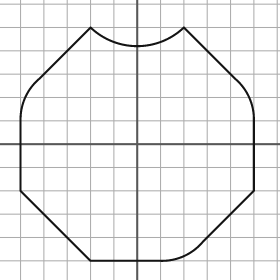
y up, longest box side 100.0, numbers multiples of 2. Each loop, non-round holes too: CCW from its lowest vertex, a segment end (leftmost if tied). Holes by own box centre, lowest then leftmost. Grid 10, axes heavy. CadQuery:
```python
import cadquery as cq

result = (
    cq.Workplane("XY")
    .moveTo(-20.0, -50.0)
    .lineTo(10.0, -50.0)
    .threePointArc((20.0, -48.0), (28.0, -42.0))
    .lineTo(50.0, -20.0)
    .lineTo(50.0, 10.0)
    .threePointArc((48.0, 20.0), (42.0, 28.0))
    .lineTo(20.0, 50.0)
    .threePointArc((0.0, 42.0), (-20.0, 50.0))
    .lineTo(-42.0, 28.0)
    .threePointArc((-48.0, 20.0), (-50.0, 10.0))
    .lineTo(-50.0, -20.0)
    .close()
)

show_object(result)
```